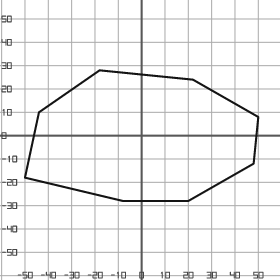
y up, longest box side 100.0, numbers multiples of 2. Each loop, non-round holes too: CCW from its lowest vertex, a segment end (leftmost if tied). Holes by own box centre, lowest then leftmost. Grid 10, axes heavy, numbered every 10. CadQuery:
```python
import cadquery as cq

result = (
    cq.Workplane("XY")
    .moveTo(-8.0, -28.0)
    .lineTo(20.0, -28.0)
    .lineTo(48.0, -12.0)
    .lineTo(50.0, 8.0)
    .lineTo(22.0, 24.0)
    .lineTo(-18.0, 28.0)
    .lineTo(-44.0, 10.0)
    .lineTo(-50.0, -18.0)
    .close()
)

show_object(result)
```